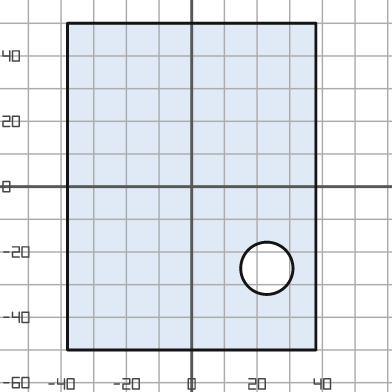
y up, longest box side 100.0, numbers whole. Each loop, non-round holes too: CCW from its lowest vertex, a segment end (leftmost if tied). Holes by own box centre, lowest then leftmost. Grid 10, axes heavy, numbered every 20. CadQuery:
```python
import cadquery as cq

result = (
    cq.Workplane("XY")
    .moveTo(-38.0, -50.0)
    .lineTo(38.0, -50.0)
    .lineTo(38.0, 50.0)
    .lineTo(-38.0, 50.0)
    .close()
    .moveTo(23.0, -25.0)
    .circle(8.0)
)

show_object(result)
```